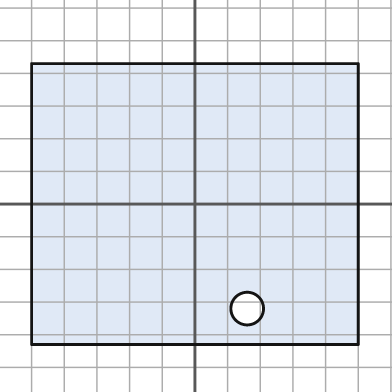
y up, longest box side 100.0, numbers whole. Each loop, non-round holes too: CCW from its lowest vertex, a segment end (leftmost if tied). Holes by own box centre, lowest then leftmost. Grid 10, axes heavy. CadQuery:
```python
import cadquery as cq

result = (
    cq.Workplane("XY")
    .moveTo(-50.0, -43.0)
    .lineTo(50.0, -43.0)
    .lineTo(50.0, 43.0)
    .lineTo(-50.0, 43.0)
    .close()
    .moveTo(16.0, -32.0)
    .circle(5.0)
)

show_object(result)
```